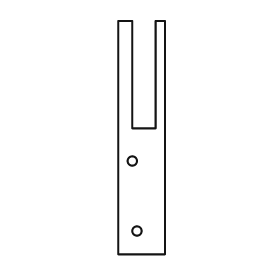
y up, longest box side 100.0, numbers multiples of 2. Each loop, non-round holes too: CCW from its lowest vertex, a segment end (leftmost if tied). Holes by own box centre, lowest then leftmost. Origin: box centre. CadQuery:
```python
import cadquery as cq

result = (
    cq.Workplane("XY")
    .moveTo(-10.0, -50.0)
    .lineTo(10.0, -50.0)
    .lineTo(10.0, 50.0)
    .lineTo(6.0, 50.0)
    .lineTo(6.0, 4.0)
    .lineTo(-4.0, 4.0)
    .lineTo(-4.0, 50.0)
    .lineTo(-10.0, 50.0)
    .close()
    .moveTo(-2.0, -40.0)
    .circle(2.0)
    .moveTo(-4.0, -10.0)
    .circle(2.0)
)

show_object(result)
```